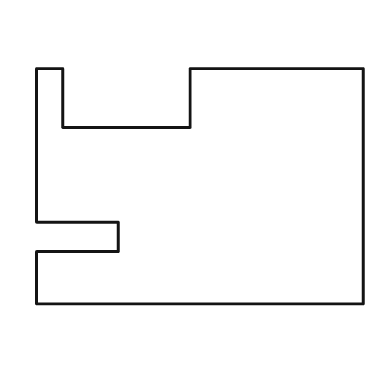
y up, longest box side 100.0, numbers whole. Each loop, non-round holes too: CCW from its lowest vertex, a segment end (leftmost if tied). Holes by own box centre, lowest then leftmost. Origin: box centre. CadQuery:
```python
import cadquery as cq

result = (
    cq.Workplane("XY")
    .moveTo(-50.0, -36.0)
    .lineTo(50.0, -36.0)
    .lineTo(50.0, 36.0)
    .lineTo(-3.0, 36.0)
    .lineTo(-3.0, 18.0)
    .lineTo(-42.0, 18.0)
    .lineTo(-42.0, 36.0)
    .lineTo(-50.0, 36.0)
    .lineTo(-50.0, -11.0)
    .lineTo(-25.0, -11.0)
    .lineTo(-25.0, -20.0)
    .lineTo(-50.0, -20.0)
    .close()
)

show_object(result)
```